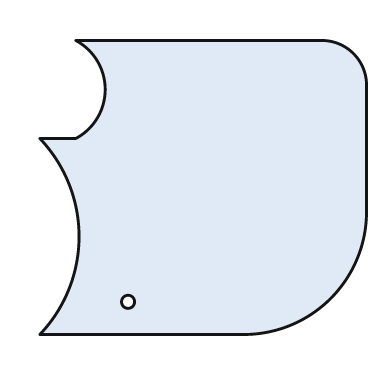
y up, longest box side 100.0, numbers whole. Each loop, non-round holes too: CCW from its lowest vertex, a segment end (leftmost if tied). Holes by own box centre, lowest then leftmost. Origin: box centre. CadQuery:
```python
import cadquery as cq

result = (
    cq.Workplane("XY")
    .moveTo(-50.0, -45.0)
    .lineTo(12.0, -45.0)
    .threePointArc((39.0, -34.0), (50.0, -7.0))
    .lineTo(50.0, 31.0)
    .threePointArc((46.0, 41.0), (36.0, 45.0))
    .lineTo(-39.0, 45.0)
    .threePointArc((-30.0, 30.0), (-39.0, 15.0))
    .lineTo(-50.0, 15.0)
    .threePointArc((-38.0, -15.0), (-50.0, -45.0))
    .close()
    .moveTo(-23.0, -35.0)
    .circle(2.0)
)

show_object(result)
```